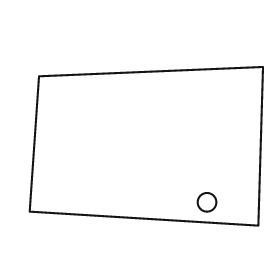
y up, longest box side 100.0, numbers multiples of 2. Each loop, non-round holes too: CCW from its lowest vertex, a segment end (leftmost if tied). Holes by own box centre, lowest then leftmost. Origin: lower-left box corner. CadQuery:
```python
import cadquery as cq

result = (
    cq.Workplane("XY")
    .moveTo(98.0, 0.0)
    .lineTo(100.0, 68.0)
    .lineTo(4.0, 64.0)
    .lineTo(0.0, 6.0)
    .close()
    .moveTo(76.0, 10.0)
    .circle(4.0)
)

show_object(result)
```